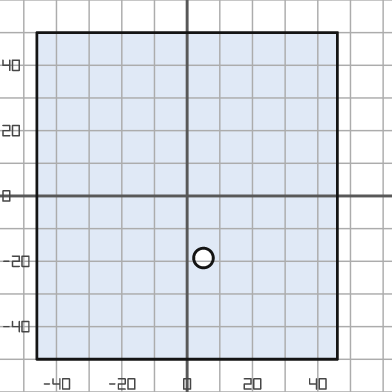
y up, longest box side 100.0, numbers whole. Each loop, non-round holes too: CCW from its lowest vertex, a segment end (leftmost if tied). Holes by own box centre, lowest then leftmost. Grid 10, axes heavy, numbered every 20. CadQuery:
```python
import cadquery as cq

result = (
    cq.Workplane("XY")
    .moveTo(-46.0, -50.0)
    .lineTo(46.0, -50.0)
    .lineTo(46.0, 50.0)
    .lineTo(-46.0, 50.0)
    .close()
    .moveTo(5.0, -19.0)
    .circle(3.0)
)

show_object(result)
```